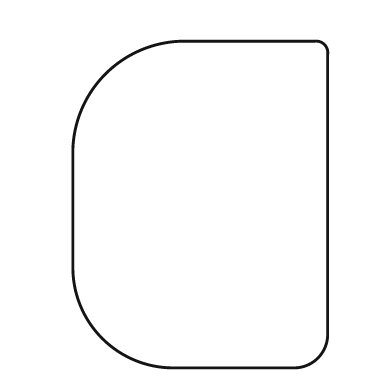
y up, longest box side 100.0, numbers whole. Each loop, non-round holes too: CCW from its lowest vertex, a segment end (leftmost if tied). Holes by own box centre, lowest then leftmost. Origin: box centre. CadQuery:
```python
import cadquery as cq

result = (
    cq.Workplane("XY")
    .moveTo(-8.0, -50.0)
    .lineTo(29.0, -50.0)
    .threePointArc((36.0, -47.0), (39.0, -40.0))
    .lineTo(39.0, 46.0)
    .threePointArc((38.0, 49.0), (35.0, 50.0))
    .lineTo(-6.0, 50.0)
    .threePointArc((-29.0, 40.0), (-39.0, 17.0))
    .lineTo(-39.0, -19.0)
    .threePointArc((-30.0, -41.0), (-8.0, -50.0))
    .close()
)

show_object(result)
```